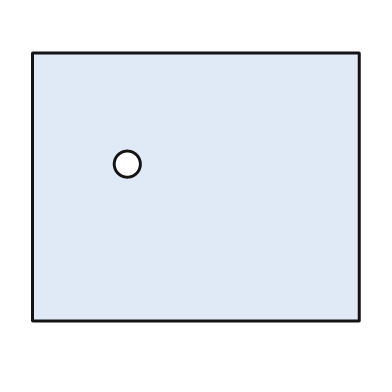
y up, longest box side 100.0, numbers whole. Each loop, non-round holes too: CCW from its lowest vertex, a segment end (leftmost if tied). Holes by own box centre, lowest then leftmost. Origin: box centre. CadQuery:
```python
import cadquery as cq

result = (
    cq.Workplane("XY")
    .moveTo(-50.0, -41.0)
    .lineTo(50.0, -41.0)
    .lineTo(50.0, 41.0)
    .lineTo(-50.0, 41.0)
    .close()
    .moveTo(-21.0, 7.0)
    .circle(4.0)
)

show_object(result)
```